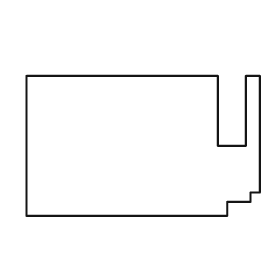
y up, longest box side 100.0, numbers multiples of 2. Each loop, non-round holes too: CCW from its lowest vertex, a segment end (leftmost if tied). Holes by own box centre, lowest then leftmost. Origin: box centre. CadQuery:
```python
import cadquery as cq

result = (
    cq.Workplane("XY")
    .moveTo(-50.0, -30.0)
    .lineTo(36.0, -30.0)
    .lineTo(36.0, -24.0)
    .lineTo(46.0, -24.0)
    .lineTo(46.0, -20.0)
    .lineTo(50.0, -20.0)
    .lineTo(50.0, 30.0)
    .lineTo(44.0, 30.0)
    .lineTo(44.0, 0.0)
    .lineTo(32.0, 0.0)
    .lineTo(32.0, 30.0)
    .lineTo(-50.0, 30.0)
    .close()
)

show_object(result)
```